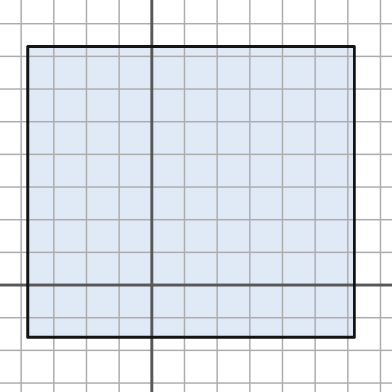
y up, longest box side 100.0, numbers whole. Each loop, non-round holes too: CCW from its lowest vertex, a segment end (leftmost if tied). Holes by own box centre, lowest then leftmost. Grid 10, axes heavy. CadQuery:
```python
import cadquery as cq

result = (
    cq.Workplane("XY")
    .moveTo(-38.0, -16.0)
    .lineTo(62.0, -16.0)
    .lineTo(62.0, 73.0)
    .lineTo(-38.0, 73.0)
    .close()
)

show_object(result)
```